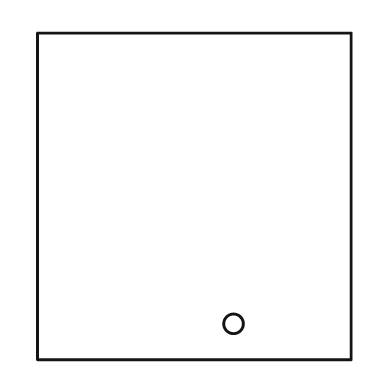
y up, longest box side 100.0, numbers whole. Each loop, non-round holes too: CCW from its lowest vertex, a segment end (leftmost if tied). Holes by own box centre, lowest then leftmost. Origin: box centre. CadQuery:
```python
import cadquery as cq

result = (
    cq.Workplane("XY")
    .moveTo(-48.0, -50.0)
    .lineTo(48.0, -50.0)
    .lineTo(48.0, 50.0)
    .lineTo(-48.0, 50.0)
    .close()
    .moveTo(12.0, -39.0)
    .circle(3.0)
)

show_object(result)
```